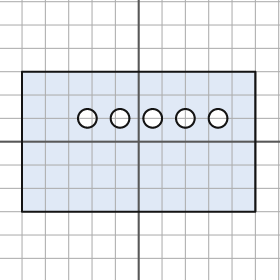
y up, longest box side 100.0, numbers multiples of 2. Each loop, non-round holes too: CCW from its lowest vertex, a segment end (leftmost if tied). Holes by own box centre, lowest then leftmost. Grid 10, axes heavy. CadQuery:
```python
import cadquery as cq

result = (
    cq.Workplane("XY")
    .moveTo(-50.0, -30.0)
    .lineTo(50.0, -30.0)
    .lineTo(50.0, 30.0)
    .lineTo(-50.0, 30.0)
    .close()
    .moveTo(-22.0, 10.0)
    .circle(4.0)
    .moveTo(-8.0, 10.0)
    .circle(4.0)
    .moveTo(6.0, 10.0)
    .circle(4.0)
    .moveTo(20.0, 10.0)
    .circle(4.0)
    .moveTo(34.0, 10.0)
    .circle(4.0)
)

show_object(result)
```